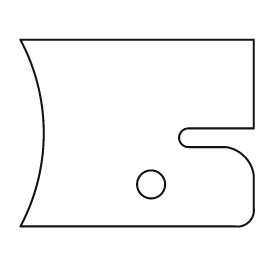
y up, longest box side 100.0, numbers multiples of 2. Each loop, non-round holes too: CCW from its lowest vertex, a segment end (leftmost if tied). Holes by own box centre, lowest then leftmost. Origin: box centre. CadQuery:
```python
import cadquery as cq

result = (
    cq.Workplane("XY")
    .moveTo(-50.0, -40.0)
    .lineTo(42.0, -40.0)
    .threePointArc((48.0, -38.0), (50.0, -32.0))
    .lineTo(50.0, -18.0)
    .threePointArc((46.0, -10.0), (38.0, -6.0))
    .lineTo(22.0, -6.0)
    .threePointArc((18.0, -2.0), (22.0, 2.0))
    .lineTo(50.0, 2.0)
    .lineTo(50.0, 40.0)
    .lineTo(-50.0, 40.0)
    .threePointArc((-40.0, 0.0), (-50.0, -40.0))
    .close()
    .moveTo(6.0, -22.0)
    .circle(6.0)
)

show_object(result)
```